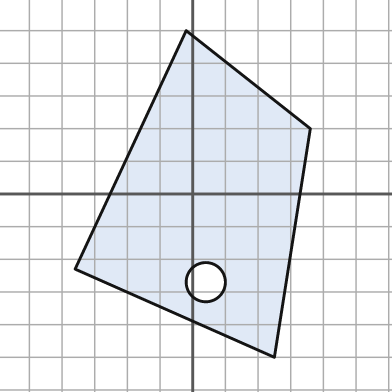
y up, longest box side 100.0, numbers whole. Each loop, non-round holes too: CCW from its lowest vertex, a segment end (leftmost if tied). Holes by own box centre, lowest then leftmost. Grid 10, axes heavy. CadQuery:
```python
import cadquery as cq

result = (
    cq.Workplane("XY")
    .moveTo(25.0, -50.0)
    .lineTo(36.0, 20.0)
    .lineTo(-2.0, 50.0)
    .lineTo(-36.0, -23.0)
    .close()
    .moveTo(4.0, -27.0)
    .circle(6.0)
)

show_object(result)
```